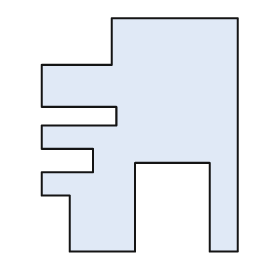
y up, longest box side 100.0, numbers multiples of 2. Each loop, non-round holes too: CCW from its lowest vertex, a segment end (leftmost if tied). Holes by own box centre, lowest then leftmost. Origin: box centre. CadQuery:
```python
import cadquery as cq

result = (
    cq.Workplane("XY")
    .moveTo(-30.0, -50.0)
    .lineTo(-2.0, -50.0)
    .lineTo(-2.0, -12.0)
    .lineTo(30.0, -12.0)
    .lineTo(30.0, -50.0)
    .lineTo(42.0, -50.0)
    .lineTo(42.0, 50.0)
    .lineTo(-12.0, 50.0)
    .lineTo(-12.0, 30.0)
    .lineTo(-42.0, 30.0)
    .lineTo(-42.0, 12.0)
    .lineTo(-10.0, 12.0)
    .lineTo(-10.0, 4.0)
    .lineTo(-42.0, 4.0)
    .lineTo(-42.0, -6.0)
    .lineTo(-20.0, -6.0)
    .lineTo(-20.0, -16.0)
    .lineTo(-42.0, -16.0)
    .lineTo(-42.0, -26.0)
    .lineTo(-30.0, -26.0)
    .close()
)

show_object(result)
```